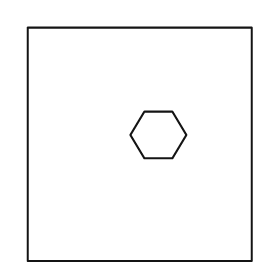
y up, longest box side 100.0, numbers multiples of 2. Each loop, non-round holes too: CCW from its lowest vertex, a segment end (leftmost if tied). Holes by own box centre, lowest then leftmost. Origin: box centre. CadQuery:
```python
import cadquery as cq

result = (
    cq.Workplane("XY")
    .moveTo(-48.0, -50.0)
    .lineTo(48.0, -50.0)
    .lineTo(48.0, 50.0)
    .lineTo(-48.0, 50.0)
    .close()
    .moveTo(2.0, -6.0)
    .lineTo(14.0, -6.0)
    .lineTo(20.0, 4.0)
    .lineTo(14.0, 14.0)
    .lineTo(2.0, 14.0)
    .lineTo(-4.0, 4.0)
    .close()
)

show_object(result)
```